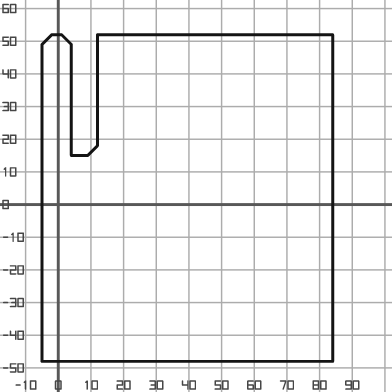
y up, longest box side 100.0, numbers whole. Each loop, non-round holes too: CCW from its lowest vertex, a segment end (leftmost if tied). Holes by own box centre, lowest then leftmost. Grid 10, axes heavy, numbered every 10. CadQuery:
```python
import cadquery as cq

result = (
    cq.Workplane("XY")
    .moveTo(-5.0, -48.0)
    .lineTo(84.0, -48.0)
    .lineTo(84.0, 52.0)
    .lineTo(12.0, 52.0)
    .lineTo(12.0, 18.0)
    .lineTo(9.0, 15.0)
    .lineTo(4.0, 15.0)
    .lineTo(4.0, 49.0)
    .lineTo(1.0, 52.0)
    .lineTo(-2.0, 52.0)
    .lineTo(-5.0, 49.0)
    .close()
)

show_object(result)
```